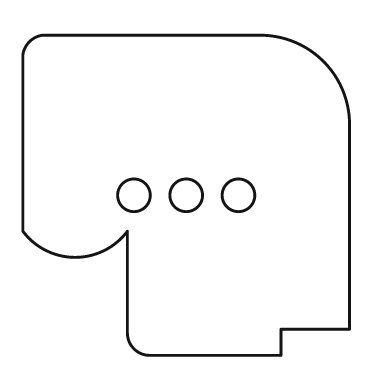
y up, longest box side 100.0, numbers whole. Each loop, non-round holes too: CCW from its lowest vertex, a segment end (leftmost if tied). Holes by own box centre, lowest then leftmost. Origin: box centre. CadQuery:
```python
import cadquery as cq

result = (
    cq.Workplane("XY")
    .moveTo(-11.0, -49.0)
    .lineTo(29.0, -49.0)
    .lineTo(29.0, -41.0)
    .lineTo(50.0, -41.0)
    .lineTo(50.0, 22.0)
    .threePointArc((42.0, 41.0), (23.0, 49.0))
    .lineTo(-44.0, 49.0)
    .threePointArc((-48.0, 47.0), (-50.0, 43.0))
    .lineTo(-50.0, -11.0)
    .threePointArc((-34.0, -19.0), (-18.0, -11.0))
    .lineTo(-18.0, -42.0)
    .threePointArc((-16.0, -47.0), (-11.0, -49.0))
    .close()
    .moveTo(-16.0, 0.0)
    .circle(5.0)
    .moveTo(0.0, 0.0)
    .circle(5.0)
    .moveTo(16.0, 0.0)
    .circle(5.0)
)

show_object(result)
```